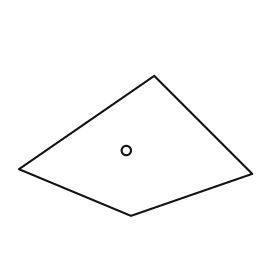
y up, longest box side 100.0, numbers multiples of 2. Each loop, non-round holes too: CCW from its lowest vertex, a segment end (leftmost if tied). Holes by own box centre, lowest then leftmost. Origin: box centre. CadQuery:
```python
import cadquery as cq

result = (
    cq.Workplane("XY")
    .moveTo(-2.0, -30.0)
    .lineTo(50.0, -12.0)
    .lineTo(8.0, 30.0)
    .lineTo(-50.0, -10.0)
    .close()
    .moveTo(-4.0, -2.0)
    .circle(2.0)
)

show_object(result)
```